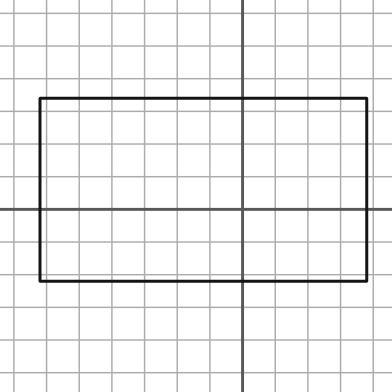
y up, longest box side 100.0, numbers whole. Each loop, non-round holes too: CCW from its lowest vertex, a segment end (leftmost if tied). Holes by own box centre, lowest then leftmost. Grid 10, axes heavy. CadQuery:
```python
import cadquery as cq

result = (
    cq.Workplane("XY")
    .moveTo(-62.0, -22.0)
    .lineTo(38.0, -22.0)
    .lineTo(38.0, 34.0)
    .lineTo(-62.0, 34.0)
    .close()
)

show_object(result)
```